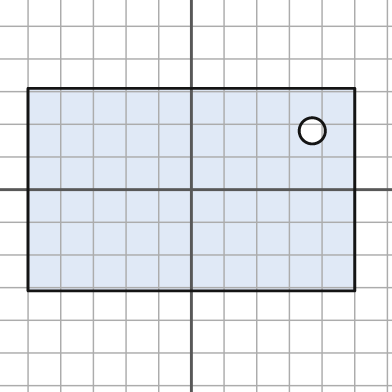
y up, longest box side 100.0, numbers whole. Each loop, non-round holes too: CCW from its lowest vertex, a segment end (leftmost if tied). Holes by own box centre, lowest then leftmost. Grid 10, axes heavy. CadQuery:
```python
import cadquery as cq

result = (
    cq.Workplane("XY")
    .moveTo(-50.0, -31.0)
    .lineTo(50.0, -31.0)
    .lineTo(50.0, 31.0)
    .lineTo(-50.0, 31.0)
    .close()
    .moveTo(37.0, 18.0)
    .circle(4.0)
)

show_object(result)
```